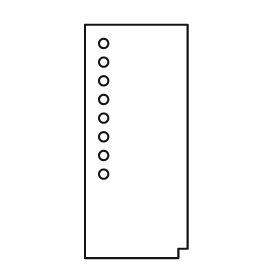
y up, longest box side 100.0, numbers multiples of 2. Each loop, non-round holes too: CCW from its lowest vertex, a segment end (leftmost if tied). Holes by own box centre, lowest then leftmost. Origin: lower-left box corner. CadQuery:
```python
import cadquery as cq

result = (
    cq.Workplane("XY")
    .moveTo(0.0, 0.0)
    .lineTo(40.0, 0.0)
    .lineTo(40.0, 4.0)
    .lineTo(44.0, 4.0)
    .lineTo(44.0, 100.0)
    .lineTo(0.0, 100.0)
    .close()
    .moveTo(8.0, 36.0)
    .circle(2.0)
    .moveTo(8.0, 44.0)
    .circle(2.0)
    .moveTo(8.0, 52.0)
    .circle(2.0)
    .moveTo(8.0, 60.0)
    .circle(2.0)
    .moveTo(8.0, 68.0)
    .circle(2.0)
    .moveTo(8.0, 76.0)
    .circle(2.0)
    .moveTo(8.0, 84.0)
    .circle(2.0)
    .moveTo(8.0, 92.0)
    .circle(2.0)
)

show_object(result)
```